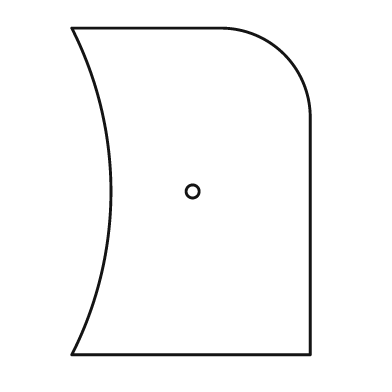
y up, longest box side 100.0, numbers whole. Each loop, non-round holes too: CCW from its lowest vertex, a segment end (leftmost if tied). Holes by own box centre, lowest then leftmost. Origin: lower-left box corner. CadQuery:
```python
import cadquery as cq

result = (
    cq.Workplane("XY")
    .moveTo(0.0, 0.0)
    .lineTo(73.0, 0.0)
    .lineTo(73.0, 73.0)
    .threePointArc((65.0, 92.0), (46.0, 100.0))
    .lineTo(0.0, 100.0)
    .threePointArc((12.0, 50.0), (0.0, 0.0))
    .close()
    .moveTo(37.0, 50.0)
    .circle(2.0)
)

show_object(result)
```